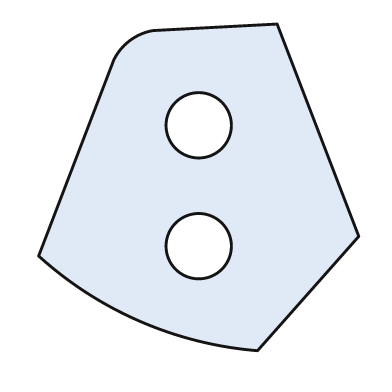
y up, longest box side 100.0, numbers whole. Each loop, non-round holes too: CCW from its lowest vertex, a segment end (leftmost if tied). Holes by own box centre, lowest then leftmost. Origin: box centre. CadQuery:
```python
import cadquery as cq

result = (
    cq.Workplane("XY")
    .moveTo(18.0, -50.0)
    .lineTo(49.0, -15.0)
    .lineTo(24.0, 50.0)
    .lineTo(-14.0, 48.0)
    .threePointArc((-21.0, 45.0), (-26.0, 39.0))
    .lineTo(-49.0, -21.0)
    .threePointArc((-18.0, -41.0), (18.0, -50.0))
    .close()
    .moveTo(0.0, -18.0)
    .circle(10.0)
    .moveTo(0.0, 19.0)
    .circle(10.0)
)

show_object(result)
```